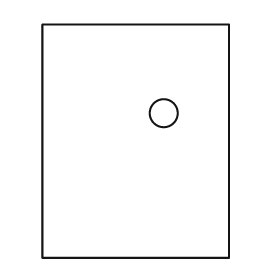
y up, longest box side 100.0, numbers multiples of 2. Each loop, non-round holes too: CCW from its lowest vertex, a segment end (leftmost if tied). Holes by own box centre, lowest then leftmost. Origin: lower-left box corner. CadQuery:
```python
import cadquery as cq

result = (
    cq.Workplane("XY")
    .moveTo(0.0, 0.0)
    .lineTo(80.0, 0.0)
    .lineTo(80.0, 100.0)
    .lineTo(0.0, 100.0)
    .close()
    .moveTo(52.0, 62.0)
    .circle(6.0)
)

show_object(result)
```